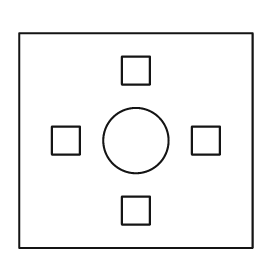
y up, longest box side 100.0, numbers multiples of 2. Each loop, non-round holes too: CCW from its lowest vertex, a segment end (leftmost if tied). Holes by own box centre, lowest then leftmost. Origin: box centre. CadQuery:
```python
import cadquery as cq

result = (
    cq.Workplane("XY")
    .moveTo(-50.0, -46.0)
    .lineTo(50.0, -46.0)
    .lineTo(50.0, 46.0)
    .lineTo(-50.0, 46.0)
    .close()
    .moveTo(-6.0, -36.0)
    .lineTo(6.0, -36.0)
    .lineTo(6.0, -24.0)
    .lineTo(-6.0, -24.0)
    .close()
    .moveTo(-36.0, -6.0)
    .lineTo(-24.0, -6.0)
    .lineTo(-24.0, 6.0)
    .lineTo(-36.0, 6.0)
    .close()
    .moveTo(0.0, 0.0)
    .circle(14.0)
    .moveTo(24.0, -6.0)
    .lineTo(36.0, -6.0)
    .lineTo(36.0, 6.0)
    .lineTo(24.0, 6.0)
    .close()
    .moveTo(-6.0, 24.0)
    .lineTo(6.0, 24.0)
    .lineTo(6.0, 36.0)
    .lineTo(-6.0, 36.0)
    .close()
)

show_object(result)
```